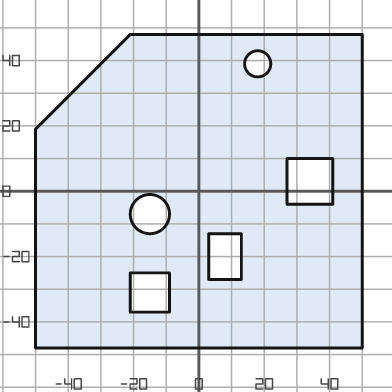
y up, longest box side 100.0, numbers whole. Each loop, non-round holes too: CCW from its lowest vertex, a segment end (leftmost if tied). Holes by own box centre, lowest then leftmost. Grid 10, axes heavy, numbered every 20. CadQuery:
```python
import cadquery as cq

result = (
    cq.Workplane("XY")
    .moveTo(-50.0, -48.0)
    .lineTo(50.0, -48.0)
    .lineTo(50.0, 48.0)
    .lineTo(-21.0, 48.0)
    .lineTo(-50.0, 19.0)
    .close()
    .moveTo(-21.0, -37.0)
    .lineTo(-9.0, -37.0)
    .lineTo(-9.0, -25.0)
    .lineTo(-21.0, -25.0)
    .close()
    .moveTo(3.0, -27.0)
    .lineTo(13.0, -27.0)
    .lineTo(13.0, -13.0)
    .lineTo(3.0, -13.0)
    .close()
    .moveTo(-15.0, -7.0)
    .circle(6.0)
    .moveTo(27.0, -4.0)
    .lineTo(41.0, -4.0)
    .lineTo(41.0, 10.0)
    .lineTo(27.0, 10.0)
    .close()
    .moveTo(18.0, 39.0)
    .circle(4.0)
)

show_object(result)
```